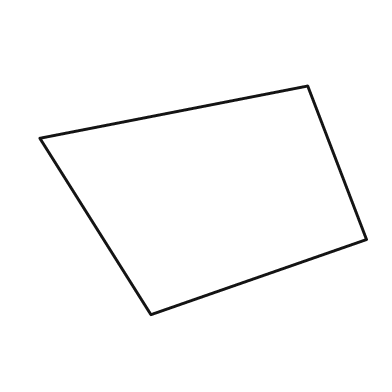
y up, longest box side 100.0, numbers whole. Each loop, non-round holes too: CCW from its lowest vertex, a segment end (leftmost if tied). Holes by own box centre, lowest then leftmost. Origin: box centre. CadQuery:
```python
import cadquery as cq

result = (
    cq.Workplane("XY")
    .moveTo(-16.0, -35.0)
    .lineTo(50.0, -12.0)
    .lineTo(32.0, 35.0)
    .lineTo(-50.0, 19.0)
    .close()
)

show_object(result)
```